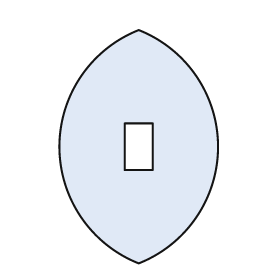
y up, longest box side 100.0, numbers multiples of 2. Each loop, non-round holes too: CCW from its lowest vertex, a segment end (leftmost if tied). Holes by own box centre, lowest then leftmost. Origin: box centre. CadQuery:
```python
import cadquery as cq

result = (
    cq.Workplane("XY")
    .moveTo(0.0, -50.0)
    .threePointArc((34.0, 0.0), (0.0, 50.0))
    .threePointArc((-34.0, 0.0), (0.0, -50.0))
    .close()
    .moveTo(-6.0, -10.0)
    .lineTo(6.0, -10.0)
    .lineTo(6.0, 10.0)
    .lineTo(-6.0, 10.0)
    .close()
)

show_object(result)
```